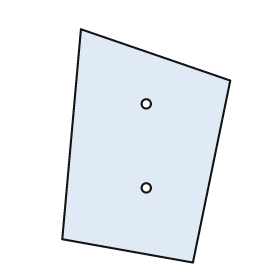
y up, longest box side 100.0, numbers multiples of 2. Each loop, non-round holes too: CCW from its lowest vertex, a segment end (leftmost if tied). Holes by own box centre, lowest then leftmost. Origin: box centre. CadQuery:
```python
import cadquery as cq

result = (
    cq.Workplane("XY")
    .moveTo(20.0, -50.0)
    .lineTo(36.0, 28.0)
    .lineTo(-28.0, 50.0)
    .lineTo(-36.0, -40.0)
    .close()
    .moveTo(0.0, -18.0)
    .circle(2.0)
    .moveTo(0.0, 18.0)
    .circle(2.0)
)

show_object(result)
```